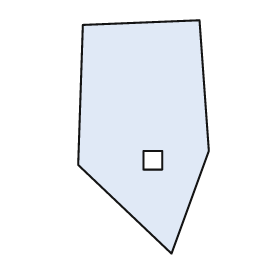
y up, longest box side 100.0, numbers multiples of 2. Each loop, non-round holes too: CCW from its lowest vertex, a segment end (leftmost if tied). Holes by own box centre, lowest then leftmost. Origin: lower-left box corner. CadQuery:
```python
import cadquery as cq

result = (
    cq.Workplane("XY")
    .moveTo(40.0, 0.0)
    .lineTo(56.0, 44.0)
    .lineTo(52.0, 100.0)
    .lineTo(2.0, 98.0)
    .lineTo(0.0, 38.0)
    .close()
    .moveTo(28.0, 36.0)
    .lineTo(36.0, 36.0)
    .lineTo(36.0, 44.0)
    .lineTo(28.0, 44.0)
    .close()
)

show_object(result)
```